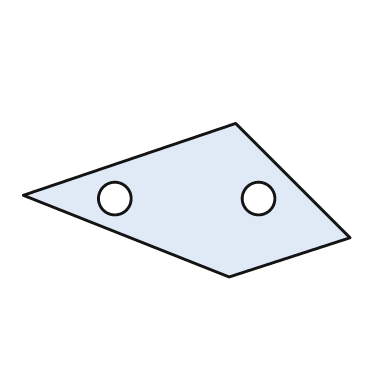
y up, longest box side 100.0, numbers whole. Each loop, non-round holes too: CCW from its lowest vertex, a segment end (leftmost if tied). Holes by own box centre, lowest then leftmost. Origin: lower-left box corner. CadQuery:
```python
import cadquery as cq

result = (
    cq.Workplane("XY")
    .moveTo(63.0, 0.0)
    .lineTo(100.0, 12.0)
    .lineTo(65.0, 47.0)
    .lineTo(0.0, 25.0)
    .close()
    .moveTo(28.0, 24.0)
    .circle(5.0)
    .moveTo(72.0, 24.0)
    .circle(5.0)
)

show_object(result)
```